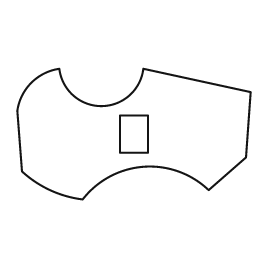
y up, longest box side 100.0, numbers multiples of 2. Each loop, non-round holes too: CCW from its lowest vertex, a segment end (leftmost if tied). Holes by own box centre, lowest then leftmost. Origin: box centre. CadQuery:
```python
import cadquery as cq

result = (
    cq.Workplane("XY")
    .moveTo(-22.0, -28.0)
    .threePointArc((4.0, -14.0), (32.0, -24.0))
    .lineTo(48.0, -10.0)
    .lineTo(50.0, 18.0)
    .lineTo(4.0, 28.0)
    .threePointArc((-14.0, 12.0), (-32.0, 28.0))
    .threePointArc((-44.0, 22.0), (-50.0, 10.0))
    .lineTo(-48.0, -16.0)
    .threePointArc((-36.0, -24.0), (-22.0, -28.0))
    .close()
    .moveTo(-6.0, -8.0)
    .lineTo(6.0, -8.0)
    .lineTo(6.0, 8.0)
    .lineTo(-6.0, 8.0)
    .close()
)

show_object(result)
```